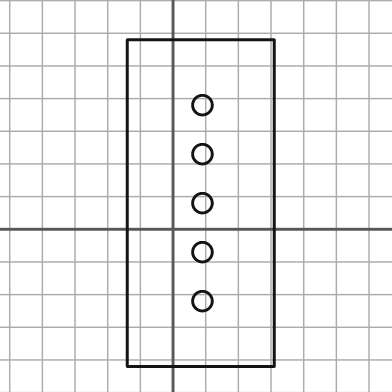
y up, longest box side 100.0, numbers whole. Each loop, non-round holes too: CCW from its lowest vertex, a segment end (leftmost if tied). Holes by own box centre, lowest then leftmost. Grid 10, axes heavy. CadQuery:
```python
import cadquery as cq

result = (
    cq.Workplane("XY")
    .moveTo(-14.0, -42.0)
    .lineTo(31.0, -42.0)
    .lineTo(31.0, 58.0)
    .lineTo(-14.0, 58.0)
    .close()
    .moveTo(9.0, -22.0)
    .circle(3.0)
    .moveTo(9.0, -7.0)
    .circle(3.0)
    .moveTo(9.0, 8.0)
    .circle(3.0)
    .moveTo(9.0, 23.0)
    .circle(3.0)
    .moveTo(9.0, 38.0)
    .circle(3.0)
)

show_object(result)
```